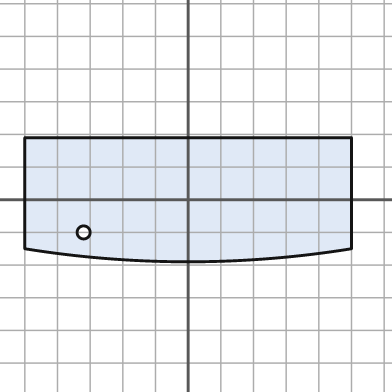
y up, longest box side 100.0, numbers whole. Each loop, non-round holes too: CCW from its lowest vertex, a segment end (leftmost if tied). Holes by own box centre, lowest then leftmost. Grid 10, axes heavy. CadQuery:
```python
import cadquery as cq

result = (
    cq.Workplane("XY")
    .moveTo(-50.0, -15.0)
    .threePointArc((0.0, -19.0), (50.0, -15.0))
    .lineTo(50.0, 19.0)
    .lineTo(-50.0, 19.0)
    .close()
    .moveTo(-32.0, -10.0)
    .circle(2.0)
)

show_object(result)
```